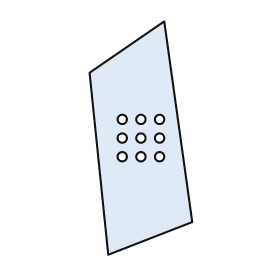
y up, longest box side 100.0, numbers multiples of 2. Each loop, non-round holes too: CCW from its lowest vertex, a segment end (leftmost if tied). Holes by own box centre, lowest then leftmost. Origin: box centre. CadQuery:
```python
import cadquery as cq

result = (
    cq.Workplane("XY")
    .moveTo(-14.0, -50.0)
    .lineTo(22.0, -36.0)
    .lineTo(10.0, 50.0)
    .lineTo(-22.0, 28.0)
    .close()
    .moveTo(-8.0, -8.0)
    .circle(2.0)
    .moveTo(0.0, -8.0)
    .circle(2.0)
    .moveTo(8.0, -8.0)
    .circle(2.0)
    .moveTo(-8.0, 0.0)
    .circle(2.0)
    .moveTo(0.0, 0.0)
    .circle(2.0)
    .moveTo(8.0, 0.0)
    .circle(2.0)
    .moveTo(-8.0, 8.0)
    .circle(2.0)
    .moveTo(0.0, 8.0)
    .circle(2.0)
    .moveTo(8.0, 8.0)
    .circle(2.0)
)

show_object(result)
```